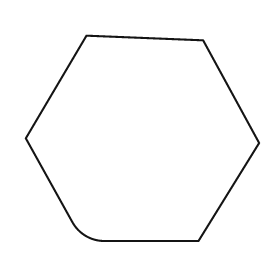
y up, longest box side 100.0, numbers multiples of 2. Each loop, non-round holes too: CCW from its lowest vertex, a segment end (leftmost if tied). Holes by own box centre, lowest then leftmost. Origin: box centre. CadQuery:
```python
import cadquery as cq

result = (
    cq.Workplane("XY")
    .moveTo(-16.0, -44.0)
    .lineTo(24.0, -44.0)
    .lineTo(50.0, -2.0)
    .lineTo(26.0, 42.0)
    .lineTo(-24.0, 44.0)
    .lineTo(-50.0, 0.0)
    .lineTo(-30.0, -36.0)
    .threePointArc((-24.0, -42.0), (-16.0, -44.0))
    .close()
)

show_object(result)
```